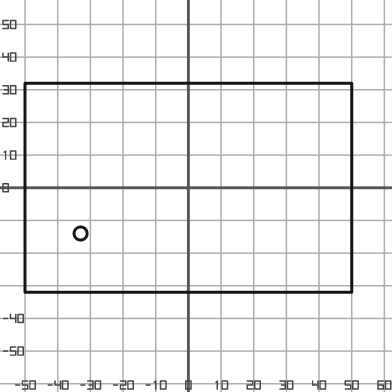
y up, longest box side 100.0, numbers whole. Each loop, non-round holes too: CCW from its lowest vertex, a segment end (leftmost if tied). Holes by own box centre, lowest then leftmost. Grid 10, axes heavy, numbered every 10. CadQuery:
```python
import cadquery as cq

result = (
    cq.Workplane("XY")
    .moveTo(-50.0, -32.0)
    .lineTo(50.0, -32.0)
    .lineTo(50.0, 32.0)
    .lineTo(-50.0, 32.0)
    .close()
    .moveTo(-33.0, -14.0)
    .circle(2.0)
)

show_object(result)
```